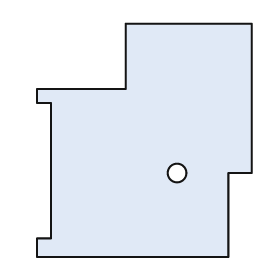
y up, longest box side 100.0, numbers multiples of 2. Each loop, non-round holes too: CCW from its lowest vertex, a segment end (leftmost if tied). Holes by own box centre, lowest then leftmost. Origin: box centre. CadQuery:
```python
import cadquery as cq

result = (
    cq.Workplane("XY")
    .moveTo(-46.0, -50.0)
    .lineTo(36.0, -50.0)
    .lineTo(36.0, -14.0)
    .lineTo(46.0, -14.0)
    .lineTo(46.0, 50.0)
    .lineTo(-8.0, 50.0)
    .lineTo(-8.0, 22.0)
    .lineTo(-46.0, 22.0)
    .lineTo(-46.0, 16.0)
    .lineTo(-40.0, 16.0)
    .lineTo(-40.0, -42.0)
    .lineTo(-46.0, -42.0)
    .close()
    .moveTo(14.0, -14.0)
    .circle(4.0)
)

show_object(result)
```